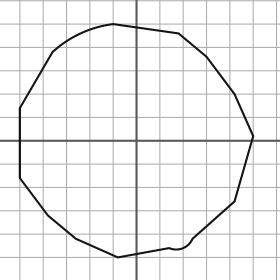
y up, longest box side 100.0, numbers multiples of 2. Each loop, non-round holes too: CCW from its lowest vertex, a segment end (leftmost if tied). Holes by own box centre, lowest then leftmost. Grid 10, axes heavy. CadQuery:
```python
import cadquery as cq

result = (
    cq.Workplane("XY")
    .moveTo(-8.0, -50.0)
    .lineTo(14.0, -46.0)
    .threePointArc((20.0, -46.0), (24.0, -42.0))
    .lineTo(42.0, -26.0)
    .lineTo(50.0, 2.0)
    .lineTo(42.0, 20.0)
    .lineTo(30.0, 36.0)
    .lineTo(18.0, 46.0)
    .lineTo(-10.0, 50.0)
    .threePointArc((-24.0, 46.0), (-36.0, 38.0))
    .lineTo(-50.0, 14.0)
    .lineTo(-50.0, -16.0)
    .lineTo(-38.0, -32.0)
    .lineTo(-26.0, -42.0)
    .close()
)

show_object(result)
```